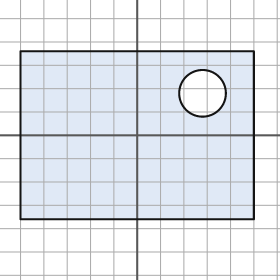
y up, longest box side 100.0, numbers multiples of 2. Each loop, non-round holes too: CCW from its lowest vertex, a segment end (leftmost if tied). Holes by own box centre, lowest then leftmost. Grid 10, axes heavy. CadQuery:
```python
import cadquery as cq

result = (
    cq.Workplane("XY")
    .moveTo(-50.0, -36.0)
    .lineTo(50.0, -36.0)
    .lineTo(50.0, 36.0)
    .lineTo(-50.0, 36.0)
    .close()
    .moveTo(28.0, 18.0)
    .circle(10.0)
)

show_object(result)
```